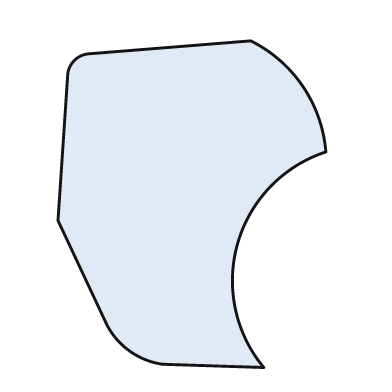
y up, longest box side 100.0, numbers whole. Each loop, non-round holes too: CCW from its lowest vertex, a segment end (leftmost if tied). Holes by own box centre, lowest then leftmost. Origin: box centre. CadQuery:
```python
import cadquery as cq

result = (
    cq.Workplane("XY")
    .moveTo(22.0, -50.0)
    .threePointArc((14.0, -12.0), (41.0, 16.0))
    .threePointArc((34.0, 36.0), (18.0, 50.0))
    .lineTo(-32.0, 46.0)
    .threePointArc((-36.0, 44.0), (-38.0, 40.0))
    .lineTo(-41.0, -5.0)
    .lineTo(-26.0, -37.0)
    .threePointArc((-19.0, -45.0), (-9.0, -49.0))
    .close()
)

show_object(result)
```